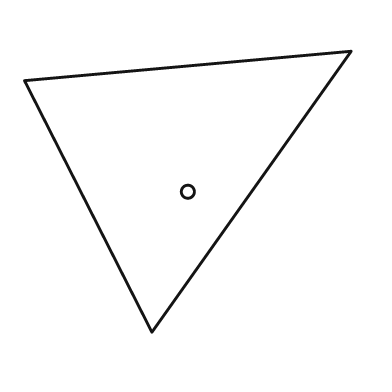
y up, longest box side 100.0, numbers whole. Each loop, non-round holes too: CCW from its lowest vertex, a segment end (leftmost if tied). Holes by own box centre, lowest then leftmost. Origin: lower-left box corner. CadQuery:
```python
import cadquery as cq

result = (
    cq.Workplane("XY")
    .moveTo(39.0, 0.0)
    .lineTo(100.0, 86.0)
    .lineTo(0.0, 77.0)
    .close()
    .moveTo(50.0, 43.0)
    .circle(2.0)
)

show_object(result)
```